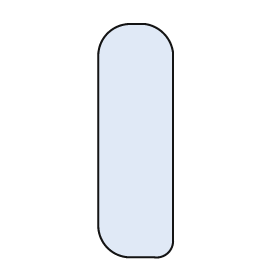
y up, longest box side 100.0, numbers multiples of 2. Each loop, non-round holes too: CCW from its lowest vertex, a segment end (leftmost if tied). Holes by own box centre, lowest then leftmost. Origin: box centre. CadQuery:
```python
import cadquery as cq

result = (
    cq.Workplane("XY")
    .moveTo(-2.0, -50.0)
    .lineTo(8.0, -50.0)
    .threePointArc((14.0, -48.0), (16.0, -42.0))
    .lineTo(16.0, 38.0)
    .threePointArc((12.0, 46.0), (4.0, 50.0))
    .lineTo(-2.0, 50.0)
    .threePointArc((-12.0, 46.0), (-16.0, 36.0))
    .lineTo(-16.0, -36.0)
    .threePointArc((-12.0, -46.0), (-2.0, -50.0))
    .close()
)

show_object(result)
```